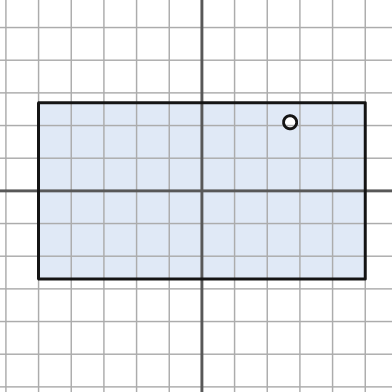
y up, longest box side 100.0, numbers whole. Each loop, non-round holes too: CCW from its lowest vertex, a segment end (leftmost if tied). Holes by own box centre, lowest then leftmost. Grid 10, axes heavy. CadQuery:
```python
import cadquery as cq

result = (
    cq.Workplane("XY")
    .moveTo(-50.0, -27.0)
    .lineTo(50.0, -27.0)
    .lineTo(50.0, 27.0)
    .lineTo(-50.0, 27.0)
    .close()
    .moveTo(27.0, 21.0)
    .circle(2.0)
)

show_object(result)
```